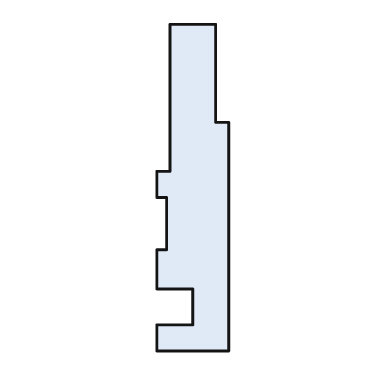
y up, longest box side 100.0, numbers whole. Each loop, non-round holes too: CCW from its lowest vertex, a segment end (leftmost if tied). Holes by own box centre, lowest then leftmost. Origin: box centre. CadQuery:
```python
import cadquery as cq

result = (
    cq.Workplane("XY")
    .moveTo(-11.0, -50.0)
    .lineTo(11.0, -50.0)
    .lineTo(11.0, 20.0)
    .lineTo(7.0, 20.0)
    .lineTo(7.0, 50.0)
    .lineTo(-7.0, 50.0)
    .lineTo(-7.0, 5.0)
    .lineTo(-11.0, 5.0)
    .lineTo(-11.0, -3.0)
    .lineTo(-8.0, -3.0)
    .lineTo(-8.0, -19.0)
    .lineTo(-11.0, -19.0)
    .lineTo(-11.0, -31.0)
    .lineTo(0.0, -31.0)
    .lineTo(0.0, -42.0)
    .lineTo(-11.0, -42.0)
    .close()
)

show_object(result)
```